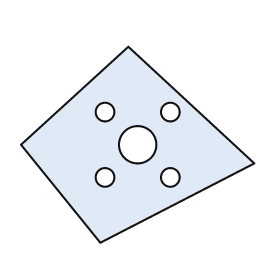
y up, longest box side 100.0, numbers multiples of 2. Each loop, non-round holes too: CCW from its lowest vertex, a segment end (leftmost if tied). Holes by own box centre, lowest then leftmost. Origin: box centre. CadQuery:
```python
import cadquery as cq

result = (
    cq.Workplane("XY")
    .moveTo(-16.0, -42.0)
    .lineTo(50.0, -8.0)
    .lineTo(-4.0, 42.0)
    .lineTo(-50.0, 0.0)
    .close()
    .moveTo(-14.0, -14.0)
    .circle(4.0)
    .moveTo(14.0, -14.0)
    .circle(4.0)
    .moveTo(0.0, 0.0)
    .circle(8.0)
    .moveTo(-14.0, 14.0)
    .circle(4.0)
    .moveTo(14.0, 14.0)
    .circle(4.0)
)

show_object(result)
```